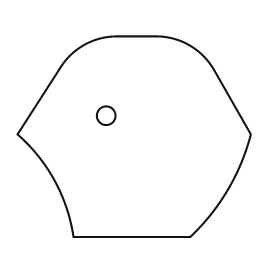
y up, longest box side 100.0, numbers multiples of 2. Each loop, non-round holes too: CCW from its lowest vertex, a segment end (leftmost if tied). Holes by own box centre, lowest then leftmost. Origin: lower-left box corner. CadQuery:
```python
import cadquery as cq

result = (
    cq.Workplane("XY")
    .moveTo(24.0, 0.0)
    .lineTo(74.0, 0.0)
    .threePointArc((90.0, 20.0), (100.0, 44.0))
    .lineTo(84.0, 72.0)
    .threePointArc((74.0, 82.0), (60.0, 86.0))
    .lineTo(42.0, 86.0)
    .threePointArc((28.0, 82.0), (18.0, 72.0))
    .lineTo(0.0, 44.0)
    .threePointArc((16.0, 24.0), (24.0, 0.0))
    .close()
    .moveTo(38.0, 52.0)
    .circle(4.0)
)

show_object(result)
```